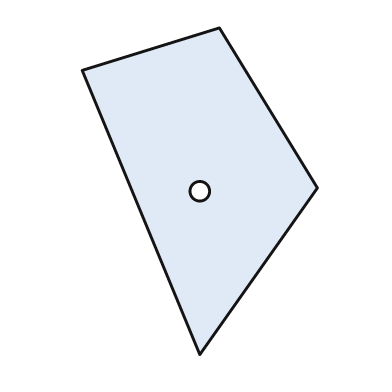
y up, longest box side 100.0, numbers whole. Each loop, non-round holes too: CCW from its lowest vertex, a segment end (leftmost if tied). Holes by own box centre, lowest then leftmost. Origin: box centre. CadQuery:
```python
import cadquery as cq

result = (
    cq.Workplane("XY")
    .moveTo(0.0, -50.0)
    .lineTo(36.0, 1.0)
    .lineTo(6.0, 50.0)
    .lineTo(-36.0, 37.0)
    .close()
    .moveTo(0.0, 0.0)
    .circle(3.0)
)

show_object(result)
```